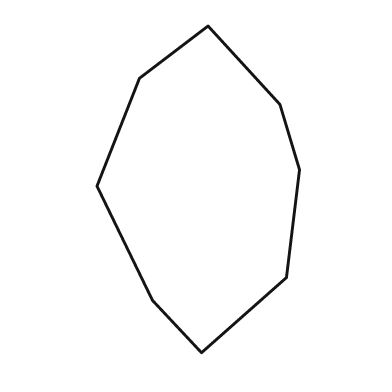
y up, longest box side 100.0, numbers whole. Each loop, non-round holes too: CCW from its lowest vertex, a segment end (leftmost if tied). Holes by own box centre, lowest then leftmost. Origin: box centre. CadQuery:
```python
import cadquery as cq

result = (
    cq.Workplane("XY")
    .moveTo(1.0, -50.0)
    .lineTo(27.0, -27.0)
    .lineTo(31.0, 6.0)
    .lineTo(25.0, 26.0)
    .lineTo(3.0, 50.0)
    .lineTo(-18.0, 34.0)
    .lineTo(-31.0, 1.0)
    .lineTo(-14.0, -34.0)
    .close()
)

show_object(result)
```